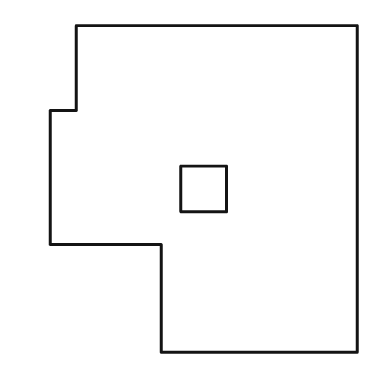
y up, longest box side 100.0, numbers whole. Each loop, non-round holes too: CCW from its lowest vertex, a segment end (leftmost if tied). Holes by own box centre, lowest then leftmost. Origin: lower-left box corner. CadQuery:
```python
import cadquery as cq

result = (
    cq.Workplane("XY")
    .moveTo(34.0, 0.0)
    .lineTo(94.0, 0.0)
    .lineTo(94.0, 100.0)
    .lineTo(8.0, 100.0)
    .lineTo(8.0, 74.0)
    .lineTo(0.0, 74.0)
    .lineTo(0.0, 33.0)
    .lineTo(34.0, 33.0)
    .close()
    .moveTo(40.0, 43.0)
    .lineTo(54.0, 43.0)
    .lineTo(54.0, 57.0)
    .lineTo(40.0, 57.0)
    .close()
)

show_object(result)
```